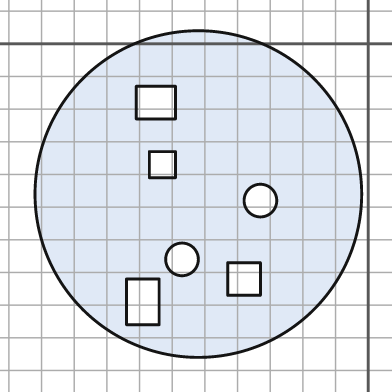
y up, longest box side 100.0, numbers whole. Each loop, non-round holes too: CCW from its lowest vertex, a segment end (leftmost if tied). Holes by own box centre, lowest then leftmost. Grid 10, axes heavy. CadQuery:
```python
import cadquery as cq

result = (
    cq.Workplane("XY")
    .moveTo(-52.0, -46.0)
    .circle(50.0)
    .moveTo(-74.0, -86.0)
    .lineTo(-64.0, -86.0)
    .lineTo(-64.0, -72.0)
    .lineTo(-74.0, -72.0)
    .close()
    .moveTo(-43.0, -77.0)
    .lineTo(-33.0, -77.0)
    .lineTo(-33.0, -67.0)
    .lineTo(-43.0, -67.0)
    .close()
    .moveTo(-57.0, -66.0)
    .circle(5.0)
    .moveTo(-33.0, -48.0)
    .circle(5.0)
    .moveTo(-67.0, -41.0)
    .lineTo(-59.0, -41.0)
    .lineTo(-59.0, -33.0)
    .lineTo(-67.0, -33.0)
    .close()
    .moveTo(-71.0, -23.0)
    .lineTo(-59.0, -23.0)
    .lineTo(-59.0, -13.0)
    .lineTo(-71.0, -13.0)
    .close()
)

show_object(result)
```